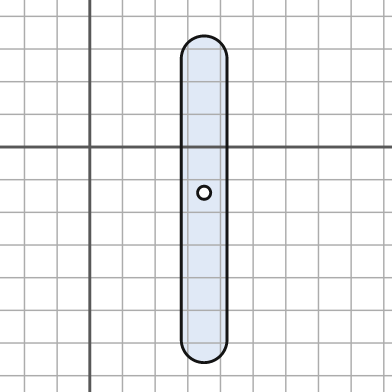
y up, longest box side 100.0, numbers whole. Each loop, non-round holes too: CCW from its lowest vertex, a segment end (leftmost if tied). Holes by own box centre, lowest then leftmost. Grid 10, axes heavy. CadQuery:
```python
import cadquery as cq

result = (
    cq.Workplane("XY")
    .moveTo(28.0, -59.0)
    .threePointArc((35.0, -66.0), (42.0, -59.0))
    .lineTo(42.0, 27.0)
    .threePointArc((35.0, 34.0), (28.0, 27.0))
    .close()
    .moveTo(35.0, -14.0)
    .circle(2.0)
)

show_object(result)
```